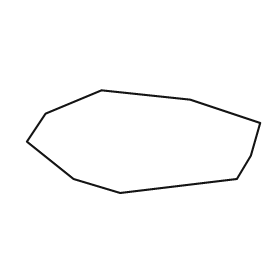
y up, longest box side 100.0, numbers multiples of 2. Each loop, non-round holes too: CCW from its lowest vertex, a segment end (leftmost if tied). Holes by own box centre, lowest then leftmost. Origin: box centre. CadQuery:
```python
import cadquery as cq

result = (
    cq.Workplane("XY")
    .moveTo(-10.0, -22.0)
    .lineTo(40.0, -16.0)
    .lineTo(46.0, -6.0)
    .lineTo(50.0, 8.0)
    .lineTo(20.0, 18.0)
    .lineTo(-18.0, 22.0)
    .lineTo(-42.0, 12.0)
    .lineTo(-50.0, 0.0)
    .lineTo(-30.0, -16.0)
    .close()
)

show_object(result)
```